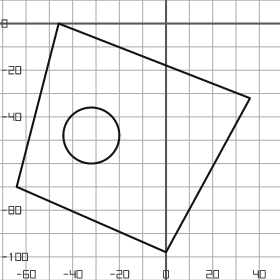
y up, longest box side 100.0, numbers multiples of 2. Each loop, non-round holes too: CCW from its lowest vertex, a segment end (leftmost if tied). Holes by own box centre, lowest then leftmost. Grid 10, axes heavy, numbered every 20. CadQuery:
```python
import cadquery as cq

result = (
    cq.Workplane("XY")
    .moveTo(0.0, -98.0)
    .lineTo(36.0, -32.0)
    .lineTo(-46.0, 0.0)
    .lineTo(-64.0, -70.0)
    .close()
    .moveTo(-32.0, -48.0)
    .circle(12.0)
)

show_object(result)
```